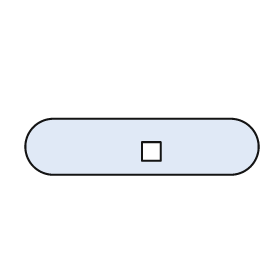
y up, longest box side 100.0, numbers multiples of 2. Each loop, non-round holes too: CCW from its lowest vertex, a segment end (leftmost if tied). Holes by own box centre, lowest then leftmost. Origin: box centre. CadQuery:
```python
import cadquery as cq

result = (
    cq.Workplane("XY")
    .moveTo(-38.0, -12.0)
    .lineTo(38.0, -12.0)
    .threePointArc((50.0, 0.0), (38.0, 12.0))
    .lineTo(-38.0, 12.0)
    .threePointArc((-50.0, 0.0), (-38.0, -12.0))
    .close()
    .moveTo(0.0, -6.0)
    .lineTo(8.0, -6.0)
    .lineTo(8.0, 2.0)
    .lineTo(0.0, 2.0)
    .close()
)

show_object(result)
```